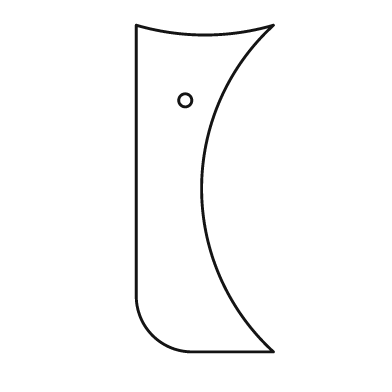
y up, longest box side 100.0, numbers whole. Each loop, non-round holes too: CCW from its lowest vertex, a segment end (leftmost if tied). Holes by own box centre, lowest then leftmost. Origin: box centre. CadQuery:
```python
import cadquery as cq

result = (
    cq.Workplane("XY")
    .moveTo(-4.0, -50.0)
    .lineTo(21.0, -50.0)
    .threePointArc((-1.0, 0.0), (21.0, 50.0))
    .threePointArc((0.0, 47.0), (-21.0, 50.0))
    .lineTo(-21.0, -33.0)
    .threePointArc((-16.0, -45.0), (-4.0, -50.0))
    .close()
    .moveTo(-6.0, 27.0)
    .circle(2.0)
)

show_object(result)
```